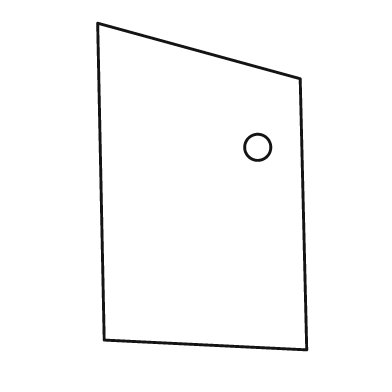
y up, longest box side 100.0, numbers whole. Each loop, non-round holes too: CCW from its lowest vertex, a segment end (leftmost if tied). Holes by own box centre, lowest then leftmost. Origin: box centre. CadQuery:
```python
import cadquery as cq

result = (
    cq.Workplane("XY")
    .moveTo(32.0, -50.0)
    .lineTo(30.0, 33.0)
    .lineTo(-32.0, 50.0)
    .lineTo(-30.0, -47.0)
    .close()
    .moveTo(17.0, 12.0)
    .circle(4.0)
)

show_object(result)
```